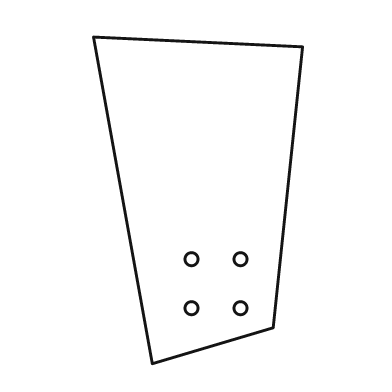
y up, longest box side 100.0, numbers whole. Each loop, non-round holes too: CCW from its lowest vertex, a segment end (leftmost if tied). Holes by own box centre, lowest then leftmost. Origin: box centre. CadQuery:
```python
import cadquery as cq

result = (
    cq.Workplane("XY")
    .moveTo(-14.0, -50.0)
    .lineTo(23.0, -39.0)
    .lineTo(32.0, 47.0)
    .lineTo(-32.0, 50.0)
    .close()
    .moveTo(-2.0, -33.0)
    .circle(2.0)
    .moveTo(13.0, -33.0)
    .circle(2.0)
    .moveTo(-2.0, -18.0)
    .circle(2.0)
    .moveTo(13.0, -18.0)
    .circle(2.0)
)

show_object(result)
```